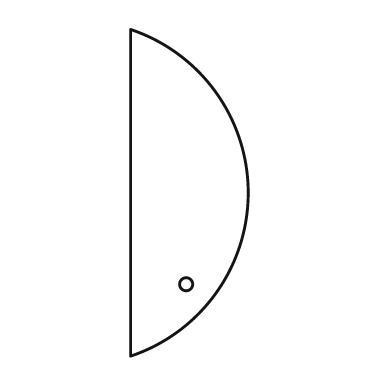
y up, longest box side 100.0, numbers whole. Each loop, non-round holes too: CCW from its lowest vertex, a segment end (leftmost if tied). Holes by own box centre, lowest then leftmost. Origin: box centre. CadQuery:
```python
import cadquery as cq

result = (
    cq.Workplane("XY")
    .moveTo(-18.0, -50.0)
    .threePointArc((18.0, 0.0), (-18.0, 50.0))
    .close()
    .moveTo(-1.0, -28.0)
    .circle(2.0)
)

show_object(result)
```